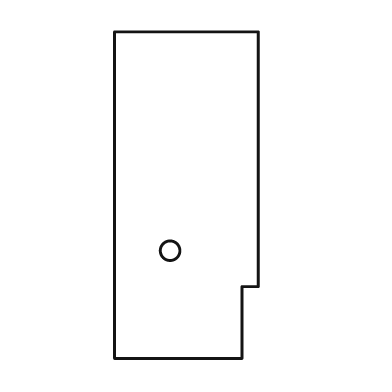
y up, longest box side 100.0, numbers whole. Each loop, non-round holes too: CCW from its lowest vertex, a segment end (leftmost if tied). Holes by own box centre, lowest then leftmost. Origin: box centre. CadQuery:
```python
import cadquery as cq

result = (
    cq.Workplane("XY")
    .moveTo(-22.0, -50.0)
    .lineTo(17.0, -50.0)
    .lineTo(17.0, -28.0)
    .lineTo(22.0, -28.0)
    .lineTo(22.0, 50.0)
    .lineTo(-22.0, 50.0)
    .close()
    .moveTo(-5.0, -17.0)
    .circle(3.0)
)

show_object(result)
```